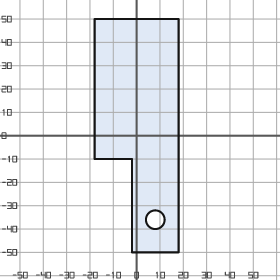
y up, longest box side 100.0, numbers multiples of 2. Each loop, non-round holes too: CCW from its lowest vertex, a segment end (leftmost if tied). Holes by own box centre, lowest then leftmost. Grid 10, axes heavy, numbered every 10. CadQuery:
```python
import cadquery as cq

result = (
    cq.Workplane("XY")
    .moveTo(-2.0, -50.0)
    .lineTo(18.0, -50.0)
    .lineTo(18.0, 50.0)
    .lineTo(-18.0, 50.0)
    .lineTo(-18.0, -10.0)
    .lineTo(-2.0, -10.0)
    .close()
    .moveTo(8.0, -36.0)
    .circle(4.0)
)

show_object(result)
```